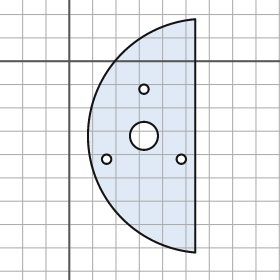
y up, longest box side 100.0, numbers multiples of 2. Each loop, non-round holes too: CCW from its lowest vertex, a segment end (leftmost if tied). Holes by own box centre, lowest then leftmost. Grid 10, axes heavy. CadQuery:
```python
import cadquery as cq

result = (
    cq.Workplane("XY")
    .moveTo(54.0, -82.0)
    .lineTo(54.0, 18.0)
    .threePointArc((8.0, -32.0), (54.0, -82.0))
    .close()
    .moveTo(16.0, -42.0)
    .circle(2.0)
    .moveTo(48.0, -42.0)
    .circle(2.0)
    .moveTo(32.0, -32.0)
    .circle(6.0)
    .moveTo(32.0, -12.0)
    .circle(2.0)
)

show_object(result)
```